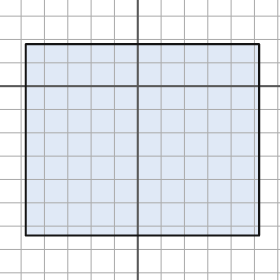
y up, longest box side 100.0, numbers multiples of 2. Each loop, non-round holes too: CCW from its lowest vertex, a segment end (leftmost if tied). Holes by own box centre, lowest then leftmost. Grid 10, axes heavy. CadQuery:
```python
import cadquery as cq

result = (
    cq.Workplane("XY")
    .moveTo(-48.0, -64.0)
    .lineTo(52.0, -64.0)
    .lineTo(52.0, 18.0)
    .lineTo(-48.0, 18.0)
    .close()
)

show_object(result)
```